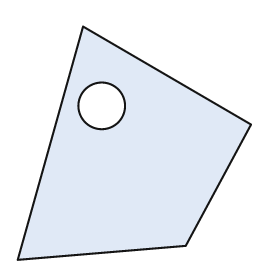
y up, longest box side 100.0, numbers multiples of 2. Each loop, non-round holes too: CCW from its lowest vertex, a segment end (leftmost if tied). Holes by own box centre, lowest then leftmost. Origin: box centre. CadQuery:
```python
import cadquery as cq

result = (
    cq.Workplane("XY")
    .moveTo(-50.0, -50.0)
    .lineTo(22.0, -44.0)
    .lineTo(50.0, 8.0)
    .lineTo(-22.0, 50.0)
    .close()
    .moveTo(-14.0, 16.0)
    .circle(10.0)
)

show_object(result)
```